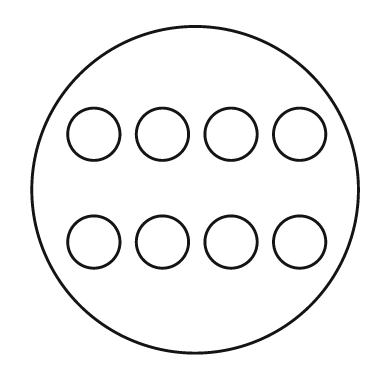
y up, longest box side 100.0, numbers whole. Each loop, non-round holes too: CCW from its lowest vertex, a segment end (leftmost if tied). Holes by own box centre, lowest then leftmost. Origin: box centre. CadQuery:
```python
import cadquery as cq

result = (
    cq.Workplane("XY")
    .moveTo(0.0, 0.0)
    .circle(50.0)
    .moveTo(-31.0, -16.0)
    .circle(8.0)
    .moveTo(-10.0, -16.0)
    .circle(8.0)
    .moveTo(11.0, -16.0)
    .circle(8.0)
    .moveTo(32.0, -16.0)
    .circle(8.0)
    .moveTo(-31.0, 17.0)
    .circle(8.0)
    .moveTo(-10.0, 17.0)
    .circle(8.0)
    .moveTo(11.0, 17.0)
    .circle(8.0)
    .moveTo(32.0, 17.0)
    .circle(8.0)
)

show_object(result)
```